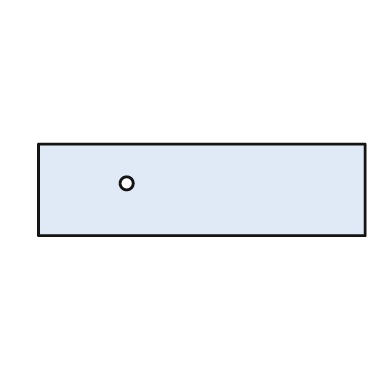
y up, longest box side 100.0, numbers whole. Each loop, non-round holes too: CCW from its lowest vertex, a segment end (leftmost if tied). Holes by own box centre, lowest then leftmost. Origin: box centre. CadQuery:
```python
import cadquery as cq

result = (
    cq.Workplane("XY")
    .moveTo(-50.0, -14.0)
    .lineTo(50.0, -14.0)
    .lineTo(50.0, 14.0)
    .lineTo(-50.0, 14.0)
    .close()
    .moveTo(-23.0, 2.0)
    .circle(2.0)
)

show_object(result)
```